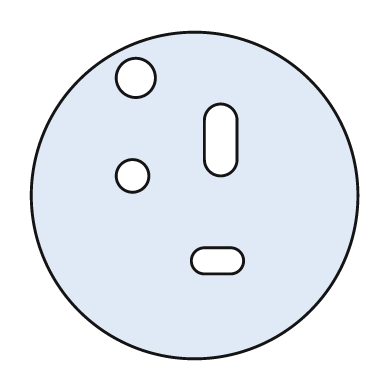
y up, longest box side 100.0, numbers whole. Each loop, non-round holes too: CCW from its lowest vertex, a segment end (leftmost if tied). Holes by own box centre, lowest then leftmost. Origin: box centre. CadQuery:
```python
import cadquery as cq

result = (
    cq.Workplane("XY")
    .moveTo(0.0, 0.0)
    .circle(50.0)
    .moveTo(3.0, -24.0)
    .lineTo(11.0, -24.0)
    .threePointArc((15.0, -20.0), (11.0, -16.0))
    .lineTo(3.0, -16.0)
    .threePointArc((-1.0, -20.0), (3.0, -24.0))
    .close()
    .moveTo(-19.0, 6.0)
    .circle(5.0)
    .moveTo(3.0, 11.0)
    .threePointArc((8.0, 6.0), (13.0, 11.0))
    .lineTo(13.0, 23.0)
    .threePointArc((8.0, 28.0), (3.0, 23.0))
    .close()
    .moveTo(-18.0, 36.0)
    .circle(6.0)
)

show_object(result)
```